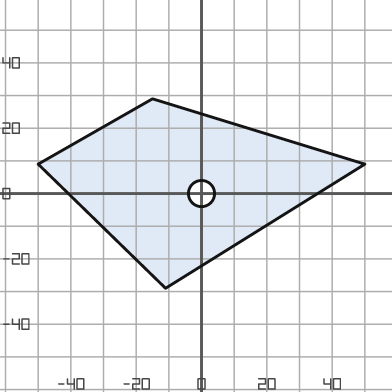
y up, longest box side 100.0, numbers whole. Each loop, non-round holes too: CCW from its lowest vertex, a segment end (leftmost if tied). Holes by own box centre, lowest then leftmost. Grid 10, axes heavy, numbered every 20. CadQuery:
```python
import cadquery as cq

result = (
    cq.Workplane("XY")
    .moveTo(-11.0, -29.0)
    .lineTo(50.0, 9.0)
    .lineTo(-15.0, 29.0)
    .lineTo(-50.0, 9.0)
    .close()
    .moveTo(0.0, 0.0)
    .circle(4.0)
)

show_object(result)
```